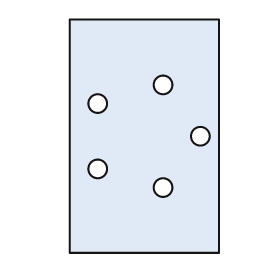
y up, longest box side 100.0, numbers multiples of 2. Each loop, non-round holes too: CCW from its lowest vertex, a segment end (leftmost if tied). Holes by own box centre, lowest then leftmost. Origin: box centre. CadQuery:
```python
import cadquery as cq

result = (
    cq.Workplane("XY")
    .moveTo(-32.0, -50.0)
    .lineTo(32.0, -50.0)
    .lineTo(32.0, 50.0)
    .lineTo(-32.0, 50.0)
    .close()
    .moveTo(8.0, -22.0)
    .circle(4.0)
    .moveTo(-20.0, -14.0)
    .circle(4.0)
    .moveTo(24.0, 0.0)
    .circle(4.0)
    .moveTo(-20.0, 14.0)
    .circle(4.0)
    .moveTo(8.0, 22.0)
    .circle(4.0)
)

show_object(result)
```